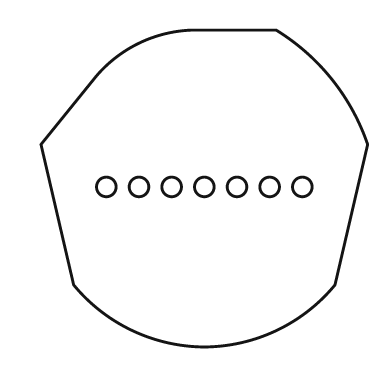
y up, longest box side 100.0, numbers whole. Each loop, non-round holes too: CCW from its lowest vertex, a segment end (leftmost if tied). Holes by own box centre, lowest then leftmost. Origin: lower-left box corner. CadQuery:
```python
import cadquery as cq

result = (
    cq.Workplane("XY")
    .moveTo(50.0, 0.0)
    .threePointArc((72.0, 5.0), (90.0, 19.0))
    .lineTo(100.0, 62.0)
    .threePointArc((89.0, 82.0), (72.0, 97.0))
    .lineTo(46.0, 97.0)
    .threePointArc((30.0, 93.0), (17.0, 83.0))
    .lineTo(0.0, 62.0)
    .lineTo(10.0, 19.0)
    .threePointArc((28.0, 5.0), (50.0, 0.0))
    .close()
    .moveTo(20.0, 49.0)
    .circle(3.0)
    .moveTo(30.0, 49.0)
    .circle(3.0)
    .moveTo(40.0, 49.0)
    .circle(3.0)
    .moveTo(50.0, 49.0)
    .circle(3.0)
    .moveTo(60.0, 49.0)
    .circle(3.0)
    .moveTo(70.0, 49.0)
    .circle(3.0)
    .moveTo(80.0, 49.0)
    .circle(3.0)
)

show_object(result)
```